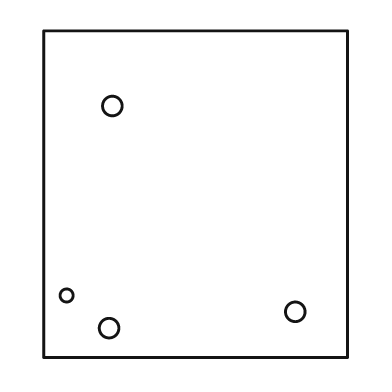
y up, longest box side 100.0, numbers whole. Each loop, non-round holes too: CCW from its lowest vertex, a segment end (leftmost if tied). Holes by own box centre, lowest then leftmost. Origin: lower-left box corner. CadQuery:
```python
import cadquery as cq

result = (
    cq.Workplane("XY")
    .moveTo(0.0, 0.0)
    .lineTo(93.0, 0.0)
    .lineTo(93.0, 100.0)
    .lineTo(0.0, 100.0)
    .close()
    .moveTo(20.0, 9.0)
    .circle(3.0)
    .moveTo(77.0, 14.0)
    .circle(3.0)
    .moveTo(7.0, 19.0)
    .circle(2.0)
    .moveTo(21.0, 77.0)
    .circle(3.0)
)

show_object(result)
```